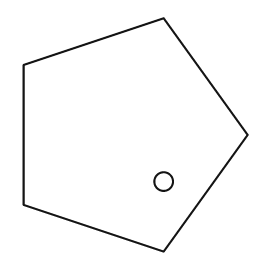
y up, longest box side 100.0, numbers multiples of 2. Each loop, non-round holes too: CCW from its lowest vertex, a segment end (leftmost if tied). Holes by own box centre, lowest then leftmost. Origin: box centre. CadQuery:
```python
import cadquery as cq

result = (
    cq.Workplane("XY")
    .moveTo(12.0, -50.0)
    .lineTo(48.0, 0.0)
    .lineTo(12.0, 50.0)
    .lineTo(-48.0, 30.0)
    .lineTo(-48.0, -30.0)
    .close()
    .moveTo(12.0, -20.0)
    .circle(4.0)
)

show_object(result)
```